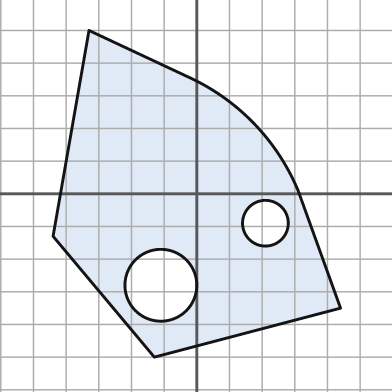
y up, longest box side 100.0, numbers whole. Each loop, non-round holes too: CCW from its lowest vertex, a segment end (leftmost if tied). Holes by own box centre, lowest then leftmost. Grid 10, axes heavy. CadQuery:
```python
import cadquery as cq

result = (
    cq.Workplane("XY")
    .moveTo(-13.0, -50.0)
    .lineTo(44.0, -35.0)
    .lineTo(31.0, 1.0)
    .threePointArc((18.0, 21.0), (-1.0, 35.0))
    .lineTo(-33.0, 50.0)
    .lineTo(-44.0, -13.0)
    .close()
    .moveTo(-11.0, -28.0)
    .circle(11.0)
    .moveTo(21.0, -9.0)
    .circle(7.0)
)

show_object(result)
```